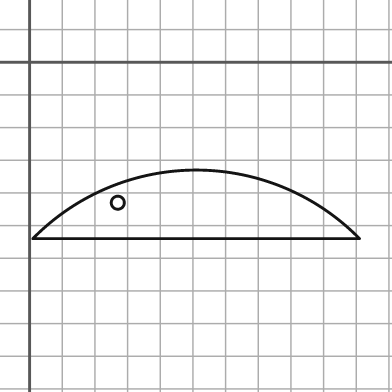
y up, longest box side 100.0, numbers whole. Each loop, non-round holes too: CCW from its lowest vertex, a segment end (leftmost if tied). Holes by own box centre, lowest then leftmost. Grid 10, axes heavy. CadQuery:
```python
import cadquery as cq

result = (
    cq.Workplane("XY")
    .moveTo(1.0, -54.0)
    .lineTo(101.0, -54.0)
    .threePointArc((51.0, -33.0), (1.0, -54.0))
    .close()
    .moveTo(27.0, -43.0)
    .circle(2.0)
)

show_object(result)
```